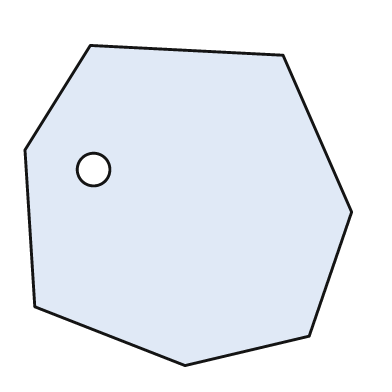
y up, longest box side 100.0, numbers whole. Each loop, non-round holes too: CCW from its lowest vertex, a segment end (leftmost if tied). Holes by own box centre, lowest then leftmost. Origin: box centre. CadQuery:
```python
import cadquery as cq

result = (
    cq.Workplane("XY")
    .moveTo(-1.0, -49.0)
    .lineTo(37.0, -40.0)
    .lineTo(50.0, -2.0)
    .lineTo(29.0, 46.0)
    .lineTo(-30.0, 49.0)
    .lineTo(-50.0, 17.0)
    .lineTo(-47.0, -31.0)
    .close()
    .moveTo(-29.0, 11.0)
    .circle(5.0)
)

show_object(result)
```